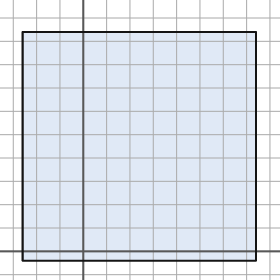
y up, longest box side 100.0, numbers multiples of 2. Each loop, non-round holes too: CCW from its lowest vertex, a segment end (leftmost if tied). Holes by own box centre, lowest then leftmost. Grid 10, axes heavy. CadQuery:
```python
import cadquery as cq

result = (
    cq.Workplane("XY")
    .moveTo(-26.0, -4.0)
    .lineTo(74.0, -4.0)
    .lineTo(74.0, 94.0)
    .lineTo(-26.0, 94.0)
    .close()
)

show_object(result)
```